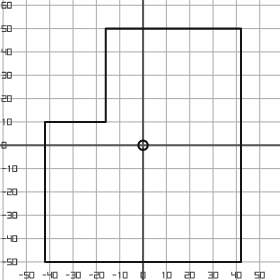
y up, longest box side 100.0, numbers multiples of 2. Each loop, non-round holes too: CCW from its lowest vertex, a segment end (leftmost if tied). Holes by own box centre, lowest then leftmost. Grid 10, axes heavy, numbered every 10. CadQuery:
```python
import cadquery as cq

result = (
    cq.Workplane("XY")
    .moveTo(-42.0, -50.0)
    .lineTo(42.0, -50.0)
    .lineTo(42.0, 50.0)
    .lineTo(-16.0, 50.0)
    .lineTo(-16.0, 10.0)
    .lineTo(-42.0, 10.0)
    .close()
    .moveTo(0.0, 0.0)
    .circle(2.0)
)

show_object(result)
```